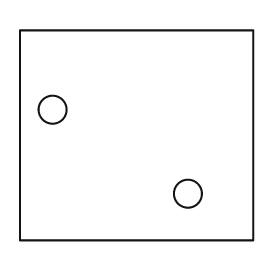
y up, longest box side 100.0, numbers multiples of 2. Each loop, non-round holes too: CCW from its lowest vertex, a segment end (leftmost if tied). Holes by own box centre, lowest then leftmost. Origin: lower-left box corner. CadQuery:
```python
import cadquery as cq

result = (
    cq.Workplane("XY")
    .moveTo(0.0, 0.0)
    .lineTo(100.0, 0.0)
    .lineTo(100.0, 90.0)
    .lineTo(0.0, 90.0)
    .close()
    .moveTo(72.0, 20.0)
    .circle(6.0)
    .moveTo(14.0, 56.0)
    .circle(6.0)
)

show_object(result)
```